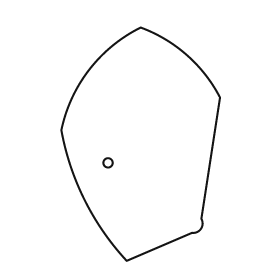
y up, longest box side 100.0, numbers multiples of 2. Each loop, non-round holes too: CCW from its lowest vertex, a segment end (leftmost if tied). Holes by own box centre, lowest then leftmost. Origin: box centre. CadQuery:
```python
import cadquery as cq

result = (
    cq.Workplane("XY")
    .moveTo(-6.0, -50.0)
    .lineTo(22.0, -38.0)
    .threePointArc((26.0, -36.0), (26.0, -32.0))
    .lineTo(34.0, 20.0)
    .threePointArc((20.0, 38.0), (0.0, 50.0))
    .threePointArc((-22.0, 32.0), (-34.0, 6.0))
    .threePointArc((-24.0, -24.0), (-6.0, -50.0))
    .close()
    .moveTo(-14.0, -8.0)
    .circle(2.0)
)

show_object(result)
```